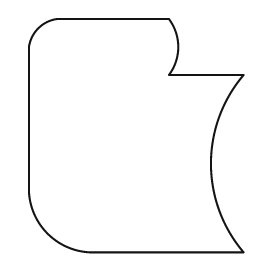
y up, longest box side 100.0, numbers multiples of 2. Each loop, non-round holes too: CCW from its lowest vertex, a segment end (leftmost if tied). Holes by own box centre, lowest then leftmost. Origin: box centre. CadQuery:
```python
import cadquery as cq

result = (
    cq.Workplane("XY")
    .moveTo(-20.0, -50.0)
    .lineTo(46.0, -50.0)
    .threePointArc((32.0, -12.0), (46.0, 26.0))
    .lineTo(14.0, 26.0)
    .threePointArc((18.0, 38.0), (14.0, 50.0))
    .lineTo(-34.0, 50.0)
    .threePointArc((-42.0, 46.0), (-46.0, 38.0))
    .lineTo(-46.0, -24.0)
    .threePointArc((-38.0, -42.0), (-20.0, -50.0))
    .close()
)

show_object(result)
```